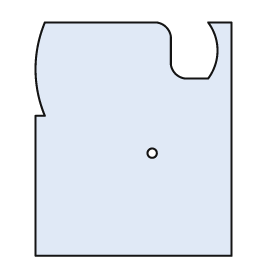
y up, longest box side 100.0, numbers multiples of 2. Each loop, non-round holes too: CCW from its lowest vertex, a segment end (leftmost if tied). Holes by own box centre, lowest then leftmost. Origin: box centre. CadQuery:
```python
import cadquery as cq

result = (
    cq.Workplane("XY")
    .moveTo(-42.0, -50.0)
    .lineTo(42.0, -50.0)
    .lineTo(42.0, 50.0)
    .lineTo(32.0, 50.0)
    .threePointArc((36.0, 38.0), (32.0, 26.0))
    .lineTo(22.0, 26.0)
    .threePointArc((18.0, 28.0), (16.0, 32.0))
    .lineTo(16.0, 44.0)
    .threePointArc((14.0, 48.0), (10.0, 50.0))
    .lineTo(-38.0, 50.0)
    .threePointArc((-42.0, 30.0), (-38.0, 10.0))
    .lineTo(-42.0, 10.0)
    .close()
    .moveTo(8.0, -6.0)
    .circle(2.0)
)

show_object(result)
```